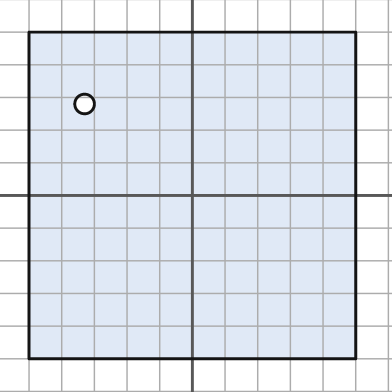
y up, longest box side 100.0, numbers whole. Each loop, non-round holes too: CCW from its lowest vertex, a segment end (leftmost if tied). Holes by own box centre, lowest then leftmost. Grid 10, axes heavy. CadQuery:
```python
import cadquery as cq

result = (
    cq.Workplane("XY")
    .moveTo(-50.0, -50.0)
    .lineTo(50.0, -50.0)
    .lineTo(50.0, 50.0)
    .lineTo(-50.0, 50.0)
    .close()
    .moveTo(-33.0, 28.0)
    .circle(3.0)
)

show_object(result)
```